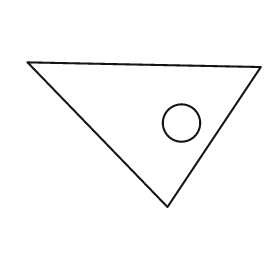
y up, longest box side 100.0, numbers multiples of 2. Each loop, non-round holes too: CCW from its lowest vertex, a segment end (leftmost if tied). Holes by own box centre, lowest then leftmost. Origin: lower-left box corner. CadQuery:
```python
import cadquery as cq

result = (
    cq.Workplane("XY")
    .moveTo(60.0, 0.0)
    .lineTo(100.0, 60.0)
    .lineTo(0.0, 62.0)
    .close()
    .moveTo(66.0, 36.0)
    .circle(8.0)
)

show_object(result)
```